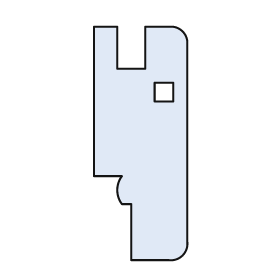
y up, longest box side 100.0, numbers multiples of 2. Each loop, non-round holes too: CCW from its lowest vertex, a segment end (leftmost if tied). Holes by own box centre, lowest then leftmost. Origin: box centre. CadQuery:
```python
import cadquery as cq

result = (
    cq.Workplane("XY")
    .moveTo(-4.0, -50.0)
    .lineTo(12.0, -50.0)
    .threePointArc((18.0, -48.0), (20.0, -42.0))
    .lineTo(20.0, 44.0)
    .threePointArc((18.0, 48.0), (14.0, 50.0))
    .lineTo(2.0, 50.0)
    .lineTo(2.0, 32.0)
    .lineTo(-10.0, 32.0)
    .lineTo(-10.0, 50.0)
    .lineTo(-20.0, 50.0)
    .lineTo(-20.0, -14.0)
    .lineTo(-8.0, -14.0)
    .threePointArc((-10.0, -20.0), (-8.0, -26.0))
    .lineTo(-4.0, -26.0)
    .close()
    .moveTo(6.0, 18.0)
    .lineTo(14.0, 18.0)
    .lineTo(14.0, 26.0)
    .lineTo(6.0, 26.0)
    .close()
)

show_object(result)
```